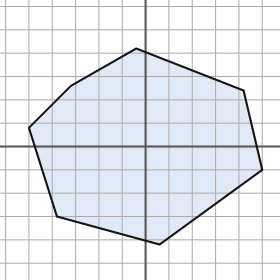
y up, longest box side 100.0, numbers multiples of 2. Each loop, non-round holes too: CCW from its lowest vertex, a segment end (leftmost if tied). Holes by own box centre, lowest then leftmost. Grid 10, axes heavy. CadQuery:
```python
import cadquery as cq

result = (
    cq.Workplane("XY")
    .moveTo(6.0, -42.0)
    .lineTo(50.0, -10.0)
    .lineTo(42.0, 24.0)
    .lineTo(-4.0, 42.0)
    .lineTo(-32.0, 26.0)
    .lineTo(-50.0, 8.0)
    .lineTo(-38.0, -30.0)
    .close()
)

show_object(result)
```